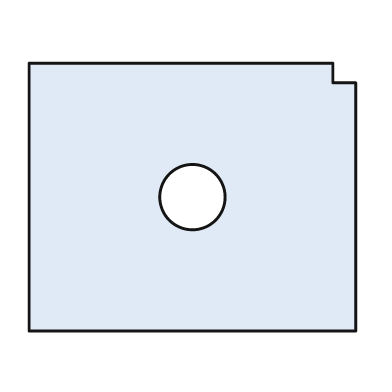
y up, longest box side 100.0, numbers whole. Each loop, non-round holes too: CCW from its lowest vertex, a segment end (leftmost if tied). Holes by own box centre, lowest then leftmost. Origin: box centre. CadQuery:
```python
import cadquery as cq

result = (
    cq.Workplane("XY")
    .moveTo(-50.0, -41.0)
    .lineTo(50.0, -41.0)
    .lineTo(50.0, 35.0)
    .lineTo(43.0, 35.0)
    .lineTo(43.0, 41.0)
    .lineTo(-50.0, 41.0)
    .close()
    .moveTo(0.0, 0.0)
    .circle(10.0)
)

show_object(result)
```